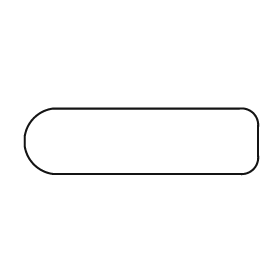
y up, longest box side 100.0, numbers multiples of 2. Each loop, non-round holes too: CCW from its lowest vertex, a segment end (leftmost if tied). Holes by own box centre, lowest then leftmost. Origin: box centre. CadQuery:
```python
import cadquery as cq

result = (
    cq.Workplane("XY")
    .moveTo(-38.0, -14.0)
    .lineTo(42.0, -14.0)
    .threePointArc((48.0, -12.0), (50.0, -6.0))
    .lineTo(50.0, 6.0)
    .threePointArc((48.0, 12.0), (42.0, 14.0))
    .lineTo(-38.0, 14.0)
    .threePointArc((-46.0, 10.0), (-50.0, 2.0))
    .lineTo(-50.0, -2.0)
    .threePointArc((-46.0, -10.0), (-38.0, -14.0))
    .close()
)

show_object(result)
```